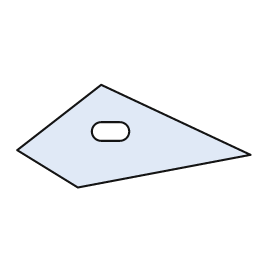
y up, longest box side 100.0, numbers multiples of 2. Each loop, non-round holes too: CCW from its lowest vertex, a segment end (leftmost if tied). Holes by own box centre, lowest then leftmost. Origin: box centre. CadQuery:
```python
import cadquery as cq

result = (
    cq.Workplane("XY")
    .moveTo(-24.0, -22.0)
    .lineTo(50.0, -8.0)
    .lineTo(-14.0, 22.0)
    .lineTo(-50.0, -6.0)
    .close()
    .moveTo(-14.0, -2.0)
    .lineTo(-6.0, -2.0)
    .threePointArc((-2.0, 2.0), (-6.0, 6.0))
    .lineTo(-14.0, 6.0)
    .threePointArc((-18.0, 2.0), (-14.0, -2.0))
    .close()
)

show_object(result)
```